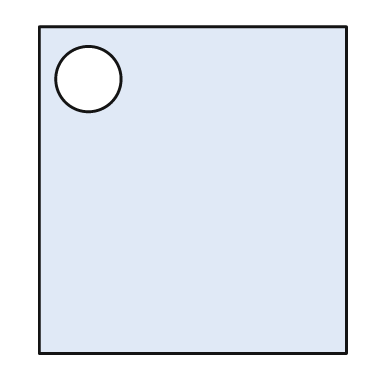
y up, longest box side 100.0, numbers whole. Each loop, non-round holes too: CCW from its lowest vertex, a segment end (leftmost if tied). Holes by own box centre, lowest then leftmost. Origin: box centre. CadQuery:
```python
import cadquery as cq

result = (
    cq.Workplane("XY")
    .moveTo(-47.0, -50.0)
    .lineTo(47.0, -50.0)
    .lineTo(47.0, 50.0)
    .lineTo(-47.0, 50.0)
    .close()
    .moveTo(-32.0, 34.0)
    .circle(10.0)
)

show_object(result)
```